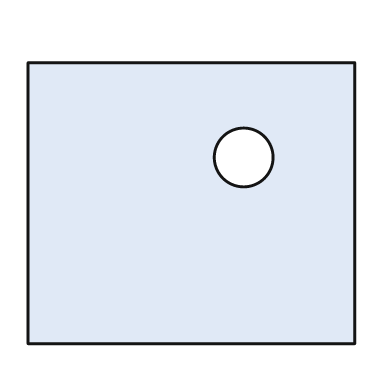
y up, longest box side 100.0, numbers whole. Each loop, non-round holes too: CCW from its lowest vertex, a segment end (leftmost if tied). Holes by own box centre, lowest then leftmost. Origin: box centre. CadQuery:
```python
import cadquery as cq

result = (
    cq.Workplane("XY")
    .moveTo(-50.0, -43.0)
    .lineTo(50.0, -43.0)
    .lineTo(50.0, 43.0)
    .lineTo(-50.0, 43.0)
    .close()
    .moveTo(16.0, 14.0)
    .circle(9.0)
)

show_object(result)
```